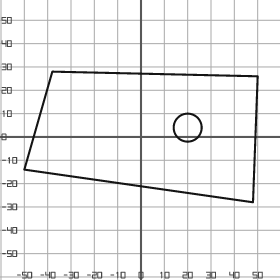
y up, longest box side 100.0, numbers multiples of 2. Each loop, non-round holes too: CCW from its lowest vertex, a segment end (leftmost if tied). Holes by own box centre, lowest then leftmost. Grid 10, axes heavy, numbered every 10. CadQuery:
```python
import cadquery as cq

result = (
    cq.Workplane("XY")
    .moveTo(48.0, -28.0)
    .lineTo(50.0, 26.0)
    .lineTo(-38.0, 28.0)
    .lineTo(-50.0, -14.0)
    .close()
    .moveTo(20.0, 4.0)
    .circle(6.0)
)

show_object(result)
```